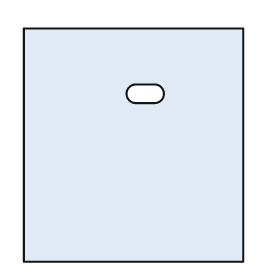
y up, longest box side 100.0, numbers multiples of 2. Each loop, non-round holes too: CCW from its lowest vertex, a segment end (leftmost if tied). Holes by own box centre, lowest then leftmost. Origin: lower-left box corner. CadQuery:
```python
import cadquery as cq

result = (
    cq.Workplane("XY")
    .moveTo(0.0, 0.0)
    .lineTo(94.0, 0.0)
    .lineTo(94.0, 100.0)
    .lineTo(0.0, 100.0)
    .close()
    .moveTo(48.0, 68.0)
    .lineTo(56.0, 68.0)
    .threePointArc((60.0, 72.0), (56.0, 76.0))
    .lineTo(48.0, 76.0)
    .threePointArc((44.0, 72.0), (48.0, 68.0))
    .close()
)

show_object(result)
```